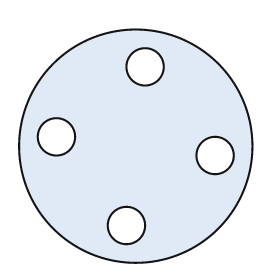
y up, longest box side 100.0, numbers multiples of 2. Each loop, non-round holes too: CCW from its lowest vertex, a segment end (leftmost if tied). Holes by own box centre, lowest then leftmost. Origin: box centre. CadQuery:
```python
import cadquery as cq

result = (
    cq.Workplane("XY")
    .moveTo(0.0, 0.0)
    .circle(50.0)
    .moveTo(-4.0, -34.0)
    .circle(8.0)
    .moveTo(34.0, -4.0)
    .circle(8.0)
    .moveTo(-34.0, 4.0)
    .circle(8.0)
    .moveTo(4.0, 34.0)
    .circle(8.0)
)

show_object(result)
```